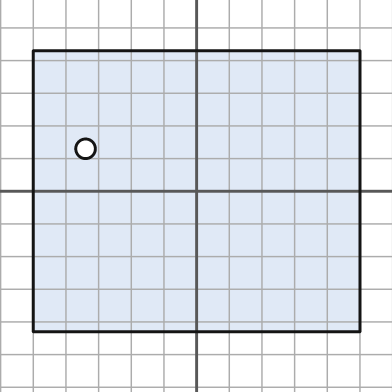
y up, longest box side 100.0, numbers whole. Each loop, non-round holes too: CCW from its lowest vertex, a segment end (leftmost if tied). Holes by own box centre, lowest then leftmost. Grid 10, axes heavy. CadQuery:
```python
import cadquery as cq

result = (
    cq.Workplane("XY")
    .moveTo(-50.0, -43.0)
    .lineTo(50.0, -43.0)
    .lineTo(50.0, 43.0)
    .lineTo(-50.0, 43.0)
    .close()
    .moveTo(-34.0, 13.0)
    .circle(3.0)
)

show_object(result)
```